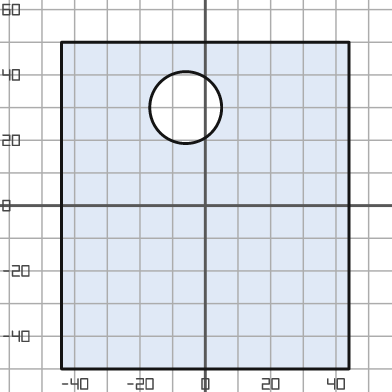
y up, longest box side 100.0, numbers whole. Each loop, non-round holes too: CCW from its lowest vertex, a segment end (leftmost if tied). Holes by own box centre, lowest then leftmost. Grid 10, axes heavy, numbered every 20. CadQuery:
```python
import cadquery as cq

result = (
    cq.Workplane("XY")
    .moveTo(-44.0, -50.0)
    .lineTo(44.0, -50.0)
    .lineTo(44.0, 50.0)
    .lineTo(-44.0, 50.0)
    .close()
    .moveTo(-6.0, 30.0)
    .circle(11.0)
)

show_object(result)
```